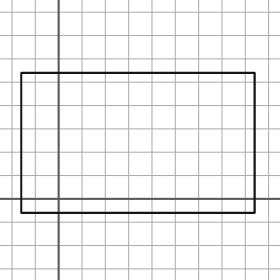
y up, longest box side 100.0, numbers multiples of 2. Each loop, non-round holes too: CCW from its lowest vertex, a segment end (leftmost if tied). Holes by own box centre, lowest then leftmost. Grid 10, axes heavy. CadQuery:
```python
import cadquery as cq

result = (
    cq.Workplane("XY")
    .moveTo(-16.0, -6.0)
    .lineTo(84.0, -6.0)
    .lineTo(84.0, 54.0)
    .lineTo(-16.0, 54.0)
    .close()
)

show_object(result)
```